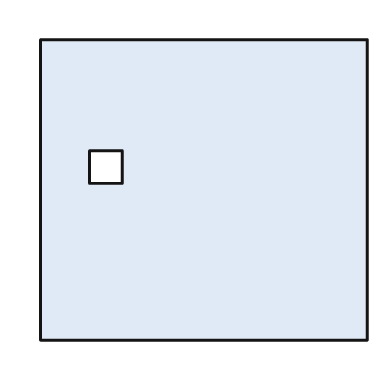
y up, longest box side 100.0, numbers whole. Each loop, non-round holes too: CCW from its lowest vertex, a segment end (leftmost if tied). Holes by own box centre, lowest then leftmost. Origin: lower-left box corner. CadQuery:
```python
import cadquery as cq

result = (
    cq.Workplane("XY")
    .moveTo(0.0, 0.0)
    .lineTo(100.0, 0.0)
    .lineTo(100.0, 92.0)
    .lineTo(0.0, 92.0)
    .close()
    .moveTo(15.0, 48.0)
    .lineTo(25.0, 48.0)
    .lineTo(25.0, 58.0)
    .lineTo(15.0, 58.0)
    .close()
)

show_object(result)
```